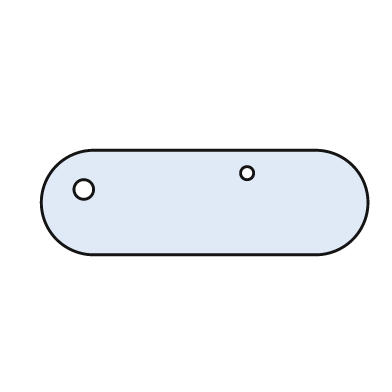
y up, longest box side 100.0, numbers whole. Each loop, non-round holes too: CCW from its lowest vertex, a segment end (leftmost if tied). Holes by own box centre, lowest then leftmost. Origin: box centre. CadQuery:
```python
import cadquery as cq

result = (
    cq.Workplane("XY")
    .moveTo(-34.0, -16.0)
    .lineTo(34.0, -16.0)
    .threePointArc((50.0, 0.0), (34.0, 16.0))
    .lineTo(-34.0, 16.0)
    .threePointArc((-50.0, 0.0), (-34.0, -16.0))
    .close()
    .moveTo(-37.0, 4.0)
    .circle(3.0)
    .moveTo(13.0, 9.0)
    .circle(2.0)
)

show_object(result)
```